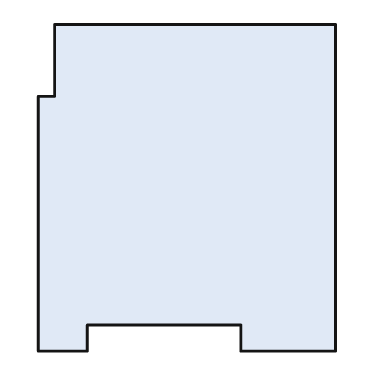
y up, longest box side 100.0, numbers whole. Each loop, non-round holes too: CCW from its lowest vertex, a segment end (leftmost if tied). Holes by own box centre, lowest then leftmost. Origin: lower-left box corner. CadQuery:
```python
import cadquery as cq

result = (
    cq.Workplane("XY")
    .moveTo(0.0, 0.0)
    .lineTo(15.0, 0.0)
    .lineTo(15.0, 8.0)
    .lineTo(62.0, 8.0)
    .lineTo(62.0, 0.0)
    .lineTo(91.0, 0.0)
    .lineTo(91.0, 100.0)
    .lineTo(5.0, 100.0)
    .lineTo(5.0, 78.0)
    .lineTo(0.0, 78.0)
    .close()
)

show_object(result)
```